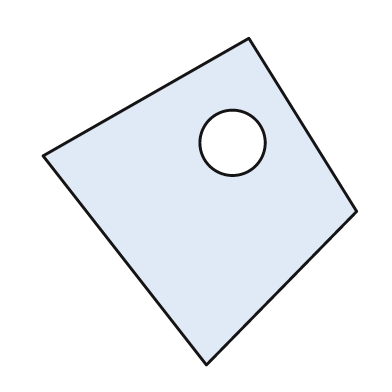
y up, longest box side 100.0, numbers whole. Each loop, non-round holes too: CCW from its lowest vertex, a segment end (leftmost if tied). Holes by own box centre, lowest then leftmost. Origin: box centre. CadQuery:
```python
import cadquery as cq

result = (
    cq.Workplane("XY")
    .moveTo(2.0, -50.0)
    .lineTo(48.0, -3.0)
    .lineTo(15.0, 50.0)
    .lineTo(-48.0, 14.0)
    .close()
    .moveTo(10.0, 18.0)
    .circle(10.0)
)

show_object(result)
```